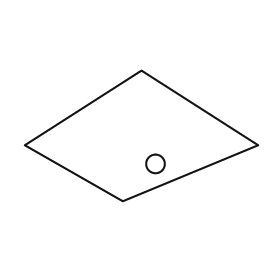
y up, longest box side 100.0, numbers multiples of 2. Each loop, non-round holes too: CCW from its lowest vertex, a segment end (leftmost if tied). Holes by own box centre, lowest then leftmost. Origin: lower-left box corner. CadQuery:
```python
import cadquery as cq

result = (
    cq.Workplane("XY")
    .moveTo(42.0, 0.0)
    .lineTo(100.0, 24.0)
    .lineTo(50.0, 56.0)
    .lineTo(0.0, 24.0)
    .close()
    .moveTo(56.0, 16.0)
    .circle(4.0)
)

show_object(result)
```